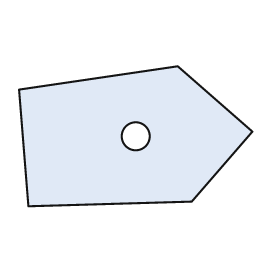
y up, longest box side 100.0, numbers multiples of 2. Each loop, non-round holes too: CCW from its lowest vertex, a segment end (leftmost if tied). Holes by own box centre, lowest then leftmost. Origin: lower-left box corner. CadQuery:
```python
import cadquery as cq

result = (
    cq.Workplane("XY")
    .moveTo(4.0, 0.0)
    .lineTo(74.0, 2.0)
    .lineTo(100.0, 32.0)
    .lineTo(68.0, 60.0)
    .lineTo(0.0, 50.0)
    .close()
    .moveTo(50.0, 30.0)
    .circle(6.0)
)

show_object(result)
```